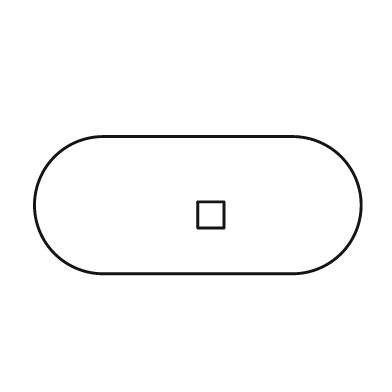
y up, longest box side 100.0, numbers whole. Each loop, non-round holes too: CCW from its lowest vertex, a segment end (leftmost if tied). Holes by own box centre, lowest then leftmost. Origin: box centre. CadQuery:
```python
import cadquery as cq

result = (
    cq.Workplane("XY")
    .moveTo(-29.0, -21.0)
    .lineTo(29.0, -21.0)
    .threePointArc((50.0, 0.0), (29.0, 21.0))
    .lineTo(-29.0, 21.0)
    .threePointArc((-50.0, 0.0), (-29.0, -21.0))
    .close()
    .moveTo(0.0, -7.0)
    .lineTo(8.0, -7.0)
    .lineTo(8.0, 1.0)
    .lineTo(0.0, 1.0)
    .close()
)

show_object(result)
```